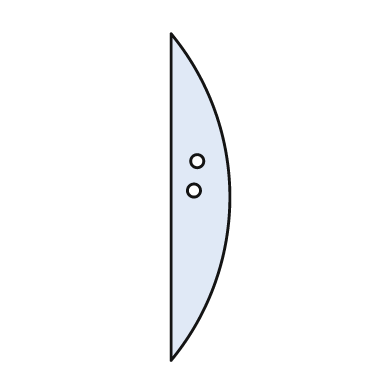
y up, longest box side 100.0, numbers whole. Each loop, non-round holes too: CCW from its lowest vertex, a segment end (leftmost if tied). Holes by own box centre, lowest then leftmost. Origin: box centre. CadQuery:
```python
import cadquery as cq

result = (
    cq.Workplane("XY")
    .moveTo(-9.0, -50.0)
    .threePointArc((9.0, 0.0), (-9.0, 50.0))
    .close()
    .moveTo(-2.0, 2.0)
    .circle(2.0)
    .moveTo(-1.0, 11.0)
    .circle(2.0)
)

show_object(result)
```